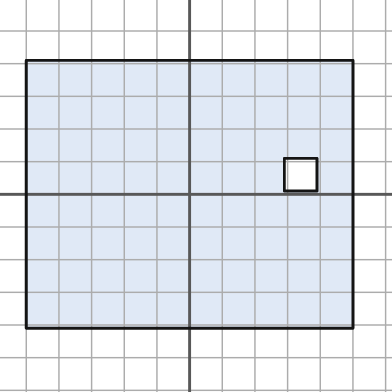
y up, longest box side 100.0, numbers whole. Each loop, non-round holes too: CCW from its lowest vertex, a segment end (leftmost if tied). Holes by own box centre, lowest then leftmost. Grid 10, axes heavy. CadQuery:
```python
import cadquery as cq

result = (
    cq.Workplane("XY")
    .moveTo(-50.0, -41.0)
    .lineTo(50.0, -41.0)
    .lineTo(50.0, 41.0)
    .lineTo(-50.0, 41.0)
    .close()
    .moveTo(29.0, 1.0)
    .lineTo(39.0, 1.0)
    .lineTo(39.0, 11.0)
    .lineTo(29.0, 11.0)
    .close()
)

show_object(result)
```